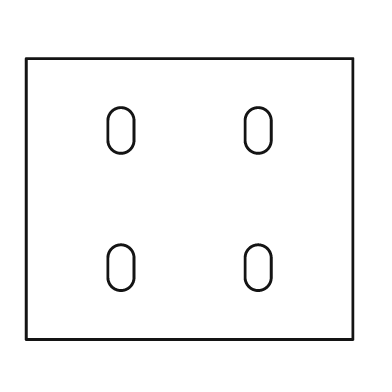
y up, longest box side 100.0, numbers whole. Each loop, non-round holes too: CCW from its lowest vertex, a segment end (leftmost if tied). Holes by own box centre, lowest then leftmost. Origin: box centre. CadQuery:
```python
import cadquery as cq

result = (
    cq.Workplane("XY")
    .moveTo(-50.0, -43.0)
    .lineTo(50.0, -43.0)
    .lineTo(50.0, 43.0)
    .lineTo(-50.0, 43.0)
    .close()
    .moveTo(-25.0, -24.0)
    .threePointArc((-21.0, -28.0), (-17.0, -24.0))
    .lineTo(-17.0, -18.0)
    .threePointArc((-21.0, -14.0), (-25.0, -18.0))
    .close()
    .moveTo(17.0, -24.0)
    .threePointArc((21.0, -28.0), (25.0, -24.0))
    .lineTo(25.0, -18.0)
    .threePointArc((21.0, -14.0), (17.0, -18.0))
    .close()
    .moveTo(-25.0, 18.0)
    .threePointArc((-21.0, 14.0), (-17.0, 18.0))
    .lineTo(-17.0, 24.0)
    .threePointArc((-21.0, 28.0), (-25.0, 24.0))
    .close()
    .moveTo(17.0, 18.0)
    .threePointArc((21.0, 14.0), (25.0, 18.0))
    .lineTo(25.0, 24.0)
    .threePointArc((21.0, 28.0), (17.0, 24.0))
    .close()
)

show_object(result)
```